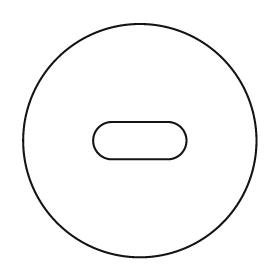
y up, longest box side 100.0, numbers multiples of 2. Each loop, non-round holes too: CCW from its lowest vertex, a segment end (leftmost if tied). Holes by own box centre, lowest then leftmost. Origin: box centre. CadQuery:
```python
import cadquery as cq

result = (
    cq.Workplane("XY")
    .moveTo(0.0, 0.0)
    .circle(50.0)
    .moveTo(-12.0, -8.0)
    .lineTo(12.0, -8.0)
    .threePointArc((20.0, 0.0), (12.0, 8.0))
    .lineTo(-12.0, 8.0)
    .threePointArc((-20.0, 0.0), (-12.0, -8.0))
    .close()
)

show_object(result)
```